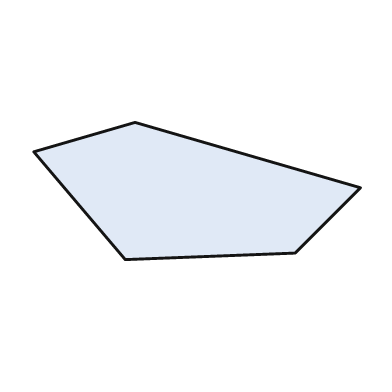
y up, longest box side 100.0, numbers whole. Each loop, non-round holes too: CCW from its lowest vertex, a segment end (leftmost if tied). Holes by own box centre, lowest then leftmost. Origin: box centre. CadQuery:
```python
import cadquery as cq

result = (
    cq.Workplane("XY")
    .moveTo(-22.0, -21.0)
    .lineTo(30.0, -19.0)
    .lineTo(50.0, 1.0)
    .lineTo(-19.0, 21.0)
    .lineTo(-50.0, 12.0)
    .close()
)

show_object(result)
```